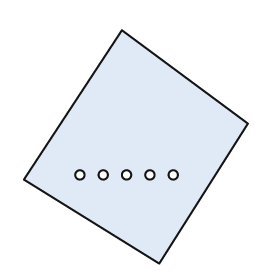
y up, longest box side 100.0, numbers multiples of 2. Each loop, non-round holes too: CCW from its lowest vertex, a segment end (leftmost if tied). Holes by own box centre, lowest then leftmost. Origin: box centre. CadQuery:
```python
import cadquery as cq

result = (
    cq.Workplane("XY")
    .moveTo(10.0, -50.0)
    .lineTo(48.0, 10.0)
    .lineTo(-6.0, 50.0)
    .lineTo(-48.0, -14.0)
    .close()
    .moveTo(-24.0, -12.0)
    .circle(2.0)
    .moveTo(-14.0, -12.0)
    .circle(2.0)
    .moveTo(-4.0, -12.0)
    .circle(2.0)
    .moveTo(6.0, -12.0)
    .circle(2.0)
    .moveTo(16.0, -12.0)
    .circle(2.0)
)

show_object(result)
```